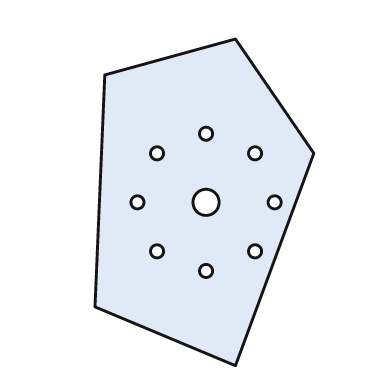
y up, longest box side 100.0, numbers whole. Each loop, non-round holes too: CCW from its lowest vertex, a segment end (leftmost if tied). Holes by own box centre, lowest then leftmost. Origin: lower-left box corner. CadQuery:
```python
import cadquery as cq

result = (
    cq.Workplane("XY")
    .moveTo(43.0, 0.0)
    .lineTo(67.0, 65.0)
    .lineTo(43.0, 100.0)
    .lineTo(3.0, 89.0)
    .lineTo(0.0, 18.0)
    .close()
    .moveTo(34.0, 29.0)
    .circle(2.0)
    .moveTo(19.0, 35.0)
    .circle(2.0)
    .moveTo(49.0, 35.0)
    .circle(2.0)
    .moveTo(13.0, 50.0)
    .circle(2.0)
    .moveTo(34.0, 50.0)
    .circle(4.0)
    .moveTo(55.0, 50.0)
    .circle(2.0)
    .moveTo(19.0, 65.0)
    .circle(2.0)
    .moveTo(49.0, 65.0)
    .circle(2.0)
    .moveTo(34.0, 71.0)
    .circle(2.0)
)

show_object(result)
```